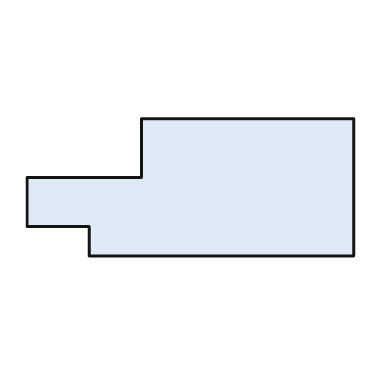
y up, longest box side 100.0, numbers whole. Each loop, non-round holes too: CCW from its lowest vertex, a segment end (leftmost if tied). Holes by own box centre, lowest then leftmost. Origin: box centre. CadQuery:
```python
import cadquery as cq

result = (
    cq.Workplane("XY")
    .moveTo(-31.0, -21.0)
    .lineTo(50.0, -21.0)
    .lineTo(50.0, 21.0)
    .lineTo(-15.0, 21.0)
    .lineTo(-15.0, 3.0)
    .lineTo(-50.0, 3.0)
    .lineTo(-50.0, -12.0)
    .lineTo(-31.0, -12.0)
    .close()
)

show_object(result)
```